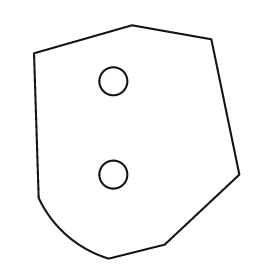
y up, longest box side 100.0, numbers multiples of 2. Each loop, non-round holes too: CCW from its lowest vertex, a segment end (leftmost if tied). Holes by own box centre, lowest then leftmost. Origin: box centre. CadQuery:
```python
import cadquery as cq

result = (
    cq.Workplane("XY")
    .moveTo(-12.0, -50.0)
    .lineTo(12.0, -44.0)
    .lineTo(44.0, -14.0)
    .lineTo(32.0, 44.0)
    .lineTo(-2.0, 50.0)
    .lineTo(-44.0, 38.0)
    .lineTo(-42.0, -24.0)
    .threePointArc((-30.0, -40.0), (-12.0, -50.0))
    .close()
    .moveTo(-10.0, -14.0)
    .circle(6.0)
    .moveTo(-10.0, 26.0)
    .circle(6.0)
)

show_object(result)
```